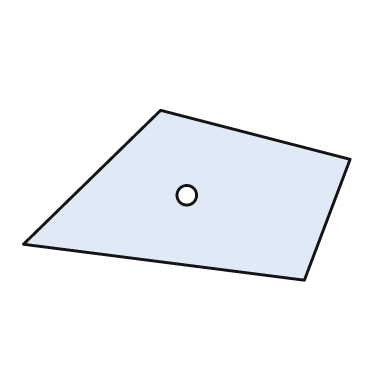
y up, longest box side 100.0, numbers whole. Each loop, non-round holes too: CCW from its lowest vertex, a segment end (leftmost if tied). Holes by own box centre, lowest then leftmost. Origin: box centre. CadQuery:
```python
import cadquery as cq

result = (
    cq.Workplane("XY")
    .moveTo(36.0, -26.0)
    .lineTo(50.0, 11.0)
    .lineTo(-8.0, 26.0)
    .lineTo(-50.0, -15.0)
    .close()
    .moveTo(0.0, 0.0)
    .circle(3.0)
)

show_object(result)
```